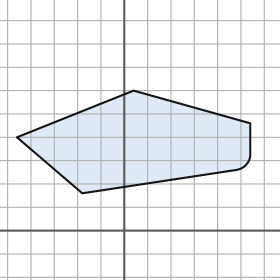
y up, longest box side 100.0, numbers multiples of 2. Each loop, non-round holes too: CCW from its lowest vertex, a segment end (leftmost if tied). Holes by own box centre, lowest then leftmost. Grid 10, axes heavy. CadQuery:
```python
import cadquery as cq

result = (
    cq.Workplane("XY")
    .moveTo(-18.0, 16.0)
    .lineTo(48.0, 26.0)
    .threePointArc((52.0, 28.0), (54.0, 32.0))
    .lineTo(54.0, 46.0)
    .lineTo(4.0, 60.0)
    .lineTo(-46.0, 40.0)
    .close()
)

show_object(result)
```